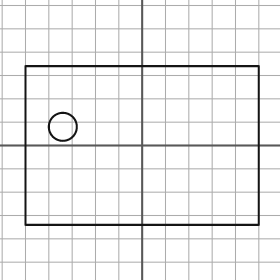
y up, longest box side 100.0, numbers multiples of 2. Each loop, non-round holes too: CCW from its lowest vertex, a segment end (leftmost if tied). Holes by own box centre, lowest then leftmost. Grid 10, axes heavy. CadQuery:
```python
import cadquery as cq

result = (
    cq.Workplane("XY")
    .moveTo(-50.0, -34.0)
    .lineTo(50.0, -34.0)
    .lineTo(50.0, 34.0)
    .lineTo(-50.0, 34.0)
    .close()
    .moveTo(-34.0, 8.0)
    .circle(6.0)
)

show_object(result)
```